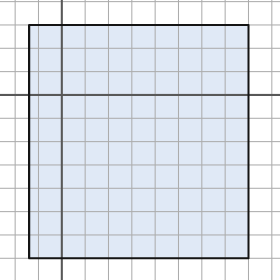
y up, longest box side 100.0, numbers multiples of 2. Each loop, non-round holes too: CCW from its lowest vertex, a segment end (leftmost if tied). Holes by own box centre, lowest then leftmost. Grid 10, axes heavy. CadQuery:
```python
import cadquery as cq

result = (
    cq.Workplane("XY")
    .moveTo(-14.0, -70.0)
    .lineTo(80.0, -70.0)
    .lineTo(80.0, 30.0)
    .lineTo(-14.0, 30.0)
    .close()
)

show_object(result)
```